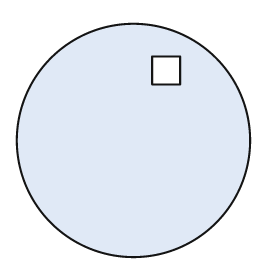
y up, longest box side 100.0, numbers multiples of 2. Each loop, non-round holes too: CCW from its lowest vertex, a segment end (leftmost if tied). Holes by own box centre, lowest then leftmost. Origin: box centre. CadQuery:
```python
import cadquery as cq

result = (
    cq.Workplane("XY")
    .moveTo(0.0, 0.0)
    .circle(50.0)
    .moveTo(8.0, 24.0)
    .lineTo(20.0, 24.0)
    .lineTo(20.0, 36.0)
    .lineTo(8.0, 36.0)
    .close()
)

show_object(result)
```